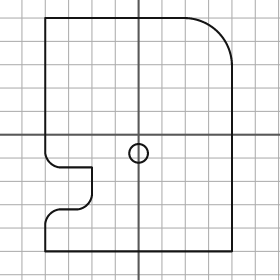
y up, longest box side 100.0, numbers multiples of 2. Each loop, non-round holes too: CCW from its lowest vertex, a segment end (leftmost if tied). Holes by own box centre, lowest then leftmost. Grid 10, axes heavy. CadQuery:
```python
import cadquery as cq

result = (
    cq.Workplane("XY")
    .moveTo(-40.0, -50.0)
    .lineTo(40.0, -50.0)
    .lineTo(40.0, 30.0)
    .threePointArc((34.0, 44.0), (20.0, 50.0))
    .lineTo(-40.0, 50.0)
    .lineTo(-40.0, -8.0)
    .threePointArc((-38.0, -12.0), (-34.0, -14.0))
    .lineTo(-20.0, -14.0)
    .lineTo(-20.0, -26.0)
    .threePointArc((-22.0, -30.0), (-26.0, -32.0))
    .lineTo(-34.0, -32.0)
    .threePointArc((-38.0, -34.0), (-40.0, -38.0))
    .close()
    .moveTo(0.0, -8.0)
    .circle(4.0)
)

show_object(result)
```